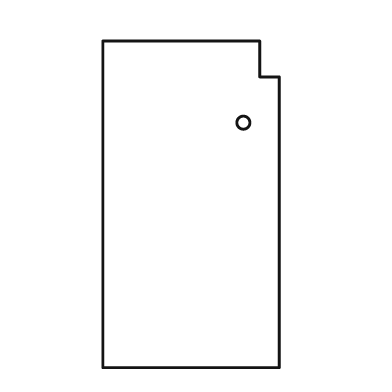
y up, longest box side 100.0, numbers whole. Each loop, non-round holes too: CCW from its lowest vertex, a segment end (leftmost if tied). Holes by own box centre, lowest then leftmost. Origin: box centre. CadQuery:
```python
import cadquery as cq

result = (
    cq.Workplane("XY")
    .moveTo(-27.0, -50.0)
    .lineTo(27.0, -50.0)
    .lineTo(27.0, 39.0)
    .lineTo(21.0, 39.0)
    .lineTo(21.0, 50.0)
    .lineTo(-27.0, 50.0)
    .close()
    .moveTo(16.0, 25.0)
    .circle(2.0)
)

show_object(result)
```